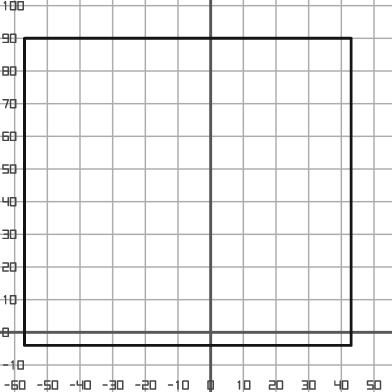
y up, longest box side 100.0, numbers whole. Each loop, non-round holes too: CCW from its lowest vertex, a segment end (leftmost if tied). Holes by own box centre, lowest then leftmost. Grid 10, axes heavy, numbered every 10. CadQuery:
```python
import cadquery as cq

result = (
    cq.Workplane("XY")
    .moveTo(-57.0, -4.0)
    .lineTo(43.0, -4.0)
    .lineTo(43.0, 90.0)
    .lineTo(-57.0, 90.0)
    .close()
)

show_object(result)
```